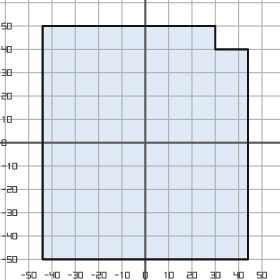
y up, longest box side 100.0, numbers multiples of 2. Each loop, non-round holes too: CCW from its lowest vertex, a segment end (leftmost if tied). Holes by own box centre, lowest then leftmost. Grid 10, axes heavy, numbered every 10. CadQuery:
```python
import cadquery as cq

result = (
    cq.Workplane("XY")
    .moveTo(-44.0, -50.0)
    .lineTo(44.0, -50.0)
    .lineTo(44.0, 40.0)
    .lineTo(30.0, 40.0)
    .lineTo(30.0, 50.0)
    .lineTo(-44.0, 50.0)
    .close()
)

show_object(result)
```